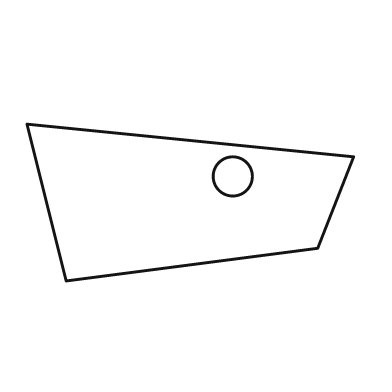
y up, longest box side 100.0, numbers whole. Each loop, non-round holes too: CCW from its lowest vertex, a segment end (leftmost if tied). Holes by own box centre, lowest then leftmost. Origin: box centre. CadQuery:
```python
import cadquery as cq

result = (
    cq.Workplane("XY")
    .moveTo(-38.0, -24.0)
    .lineTo(39.0, -14.0)
    .lineTo(50.0, 14.0)
    .lineTo(-50.0, 24.0)
    .close()
    .moveTo(13.0, 8.0)
    .circle(6.0)
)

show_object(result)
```